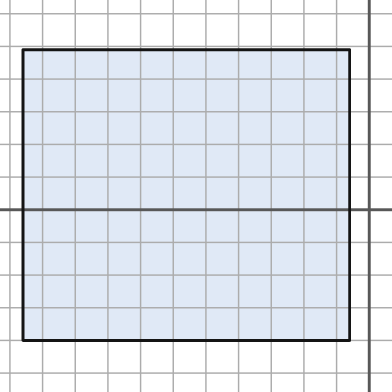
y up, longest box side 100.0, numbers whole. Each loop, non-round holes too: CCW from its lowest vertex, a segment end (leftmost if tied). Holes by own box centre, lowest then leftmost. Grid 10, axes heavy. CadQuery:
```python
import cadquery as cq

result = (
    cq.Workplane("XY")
    .moveTo(-106.0, -40.0)
    .lineTo(-6.0, -40.0)
    .lineTo(-6.0, 49.0)
    .lineTo(-106.0, 49.0)
    .close()
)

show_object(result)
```